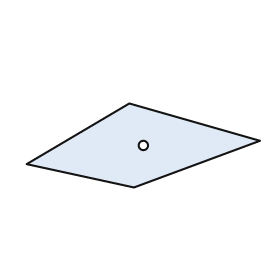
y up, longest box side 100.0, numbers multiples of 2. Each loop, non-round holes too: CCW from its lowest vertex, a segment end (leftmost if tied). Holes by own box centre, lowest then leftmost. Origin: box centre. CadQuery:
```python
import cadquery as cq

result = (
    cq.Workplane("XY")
    .moveTo(-4.0, -18.0)
    .lineTo(50.0, 2.0)
    .lineTo(-6.0, 18.0)
    .lineTo(-50.0, -8.0)
    .close()
    .moveTo(0.0, 0.0)
    .circle(2.0)
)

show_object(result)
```